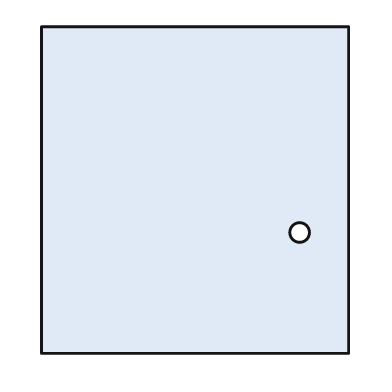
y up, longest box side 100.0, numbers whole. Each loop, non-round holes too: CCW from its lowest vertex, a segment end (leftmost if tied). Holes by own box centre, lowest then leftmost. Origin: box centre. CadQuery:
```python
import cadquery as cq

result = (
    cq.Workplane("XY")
    .moveTo(-47.0, -50.0)
    .lineTo(47.0, -50.0)
    .lineTo(47.0, 50.0)
    .lineTo(-47.0, 50.0)
    .close()
    .moveTo(32.0, -13.0)
    .circle(3.0)
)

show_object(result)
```